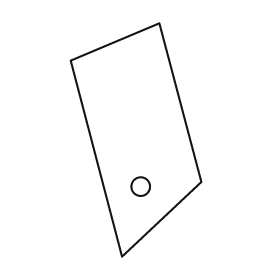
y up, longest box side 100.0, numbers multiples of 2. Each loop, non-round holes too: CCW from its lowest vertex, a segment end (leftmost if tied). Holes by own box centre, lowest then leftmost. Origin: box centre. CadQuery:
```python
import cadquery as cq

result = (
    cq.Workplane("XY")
    .moveTo(-6.0, -50.0)
    .lineTo(28.0, -18.0)
    .lineTo(10.0, 50.0)
    .lineTo(-28.0, 34.0)
    .close()
    .moveTo(2.0, -20.0)
    .circle(4.0)
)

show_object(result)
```